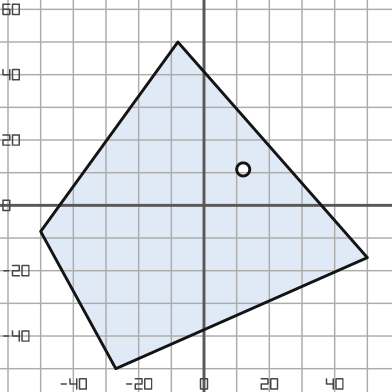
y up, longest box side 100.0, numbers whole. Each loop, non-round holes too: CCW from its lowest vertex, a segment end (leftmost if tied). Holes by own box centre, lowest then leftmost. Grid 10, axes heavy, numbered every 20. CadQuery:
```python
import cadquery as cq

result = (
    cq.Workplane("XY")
    .moveTo(-27.0, -50.0)
    .lineTo(50.0, -16.0)
    .lineTo(-8.0, 50.0)
    .lineTo(-50.0, -8.0)
    .close()
    .moveTo(12.0, 11.0)
    .circle(2.0)
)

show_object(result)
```